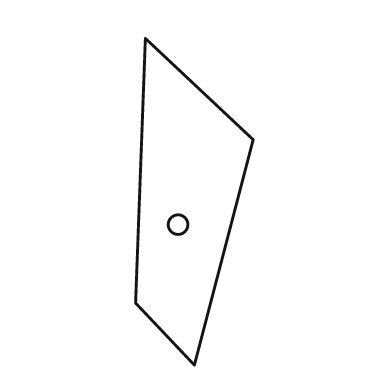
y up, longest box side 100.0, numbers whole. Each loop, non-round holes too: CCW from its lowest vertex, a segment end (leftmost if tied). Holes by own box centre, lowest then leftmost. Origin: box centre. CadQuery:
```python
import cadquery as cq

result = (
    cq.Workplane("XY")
    .moveTo(0.0, -50.0)
    .lineTo(18.0, 19.0)
    .lineTo(-15.0, 50.0)
    .lineTo(-18.0, -31.0)
    .close()
    .moveTo(-5.0, -7.0)
    .circle(3.0)
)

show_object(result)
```